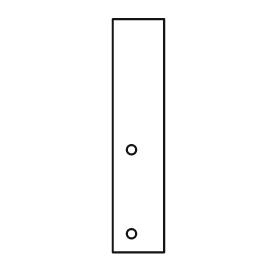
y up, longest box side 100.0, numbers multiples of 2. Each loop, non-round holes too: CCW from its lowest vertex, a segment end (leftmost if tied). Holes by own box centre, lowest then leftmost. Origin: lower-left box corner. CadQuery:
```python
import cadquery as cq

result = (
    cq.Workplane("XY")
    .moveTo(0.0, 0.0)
    .lineTo(22.0, 0.0)
    .lineTo(22.0, 100.0)
    .lineTo(0.0, 100.0)
    .close()
    .moveTo(8.0, 8.0)
    .circle(2.0)
    .moveTo(8.0, 44.0)
    .circle(2.0)
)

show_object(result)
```